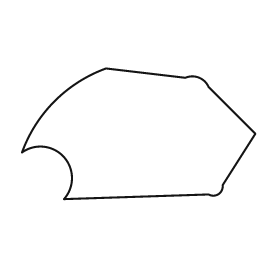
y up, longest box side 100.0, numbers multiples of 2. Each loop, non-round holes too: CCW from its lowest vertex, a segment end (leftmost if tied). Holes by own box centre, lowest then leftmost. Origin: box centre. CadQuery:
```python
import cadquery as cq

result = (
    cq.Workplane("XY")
    .moveTo(-32.0, -28.0)
    .lineTo(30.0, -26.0)
    .threePointArc((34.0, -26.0), (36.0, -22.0))
    .lineTo(50.0, 0.0)
    .lineTo(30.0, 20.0)
    .threePointArc((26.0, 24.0), (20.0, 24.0))
    .lineTo(-14.0, 28.0)
    .threePointArc((-36.0, 14.0), (-50.0, -8.0))
    .threePointArc((-32.0, -10.0), (-32.0, -28.0))
    .close()
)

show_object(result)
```